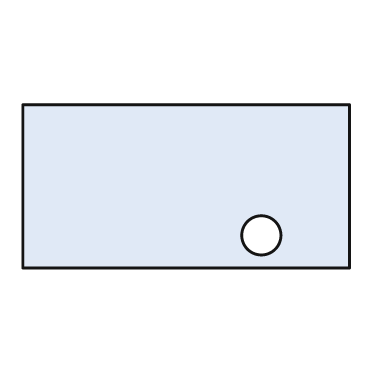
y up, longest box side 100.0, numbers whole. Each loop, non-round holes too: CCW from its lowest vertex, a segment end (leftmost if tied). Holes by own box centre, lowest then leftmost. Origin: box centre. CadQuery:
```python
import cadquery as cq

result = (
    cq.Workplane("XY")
    .moveTo(-50.0, -25.0)
    .lineTo(50.0, -25.0)
    .lineTo(50.0, 25.0)
    .lineTo(-50.0, 25.0)
    .close()
    .moveTo(23.0, -15.0)
    .circle(6.0)
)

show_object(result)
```